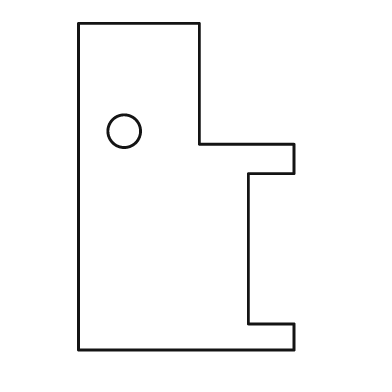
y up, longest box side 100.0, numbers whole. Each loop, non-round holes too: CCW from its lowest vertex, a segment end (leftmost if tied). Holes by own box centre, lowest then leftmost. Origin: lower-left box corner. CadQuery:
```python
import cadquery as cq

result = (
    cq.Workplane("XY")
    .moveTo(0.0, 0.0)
    .lineTo(66.0, 0.0)
    .lineTo(66.0, 8.0)
    .lineTo(52.0, 8.0)
    .lineTo(52.0, 54.0)
    .lineTo(66.0, 54.0)
    .lineTo(66.0, 63.0)
    .lineTo(37.0, 63.0)
    .lineTo(37.0, 100.0)
    .lineTo(0.0, 100.0)
    .close()
    .moveTo(14.0, 67.0)
    .circle(5.0)
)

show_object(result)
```